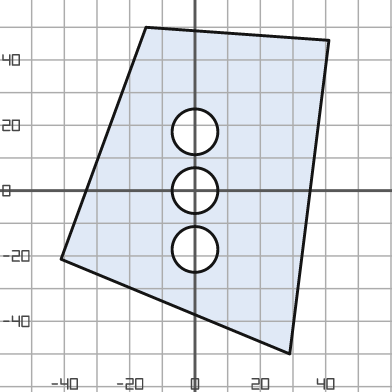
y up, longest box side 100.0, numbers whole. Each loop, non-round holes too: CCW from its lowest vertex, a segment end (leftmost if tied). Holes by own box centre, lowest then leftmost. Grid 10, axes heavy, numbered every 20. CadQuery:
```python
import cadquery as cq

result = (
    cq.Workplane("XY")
    .moveTo(29.0, -50.0)
    .lineTo(41.0, 46.0)
    .lineTo(-15.0, 50.0)
    .lineTo(-41.0, -21.0)
    .close()
    .moveTo(0.0, -18.0)
    .circle(7.0)
    .moveTo(0.0, 0.0)
    .circle(7.0)
    .moveTo(0.0, 18.0)
    .circle(7.0)
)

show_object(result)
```